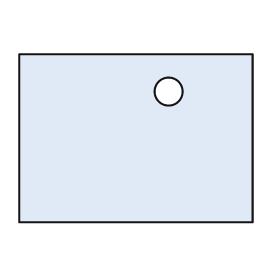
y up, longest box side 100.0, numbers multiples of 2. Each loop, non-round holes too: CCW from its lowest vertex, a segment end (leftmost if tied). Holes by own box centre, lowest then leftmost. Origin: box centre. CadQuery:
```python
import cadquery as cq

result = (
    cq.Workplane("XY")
    .moveTo(-50.0, -36.0)
    .lineTo(50.0, -36.0)
    .lineTo(50.0, 36.0)
    .lineTo(-50.0, 36.0)
    .close()
    .moveTo(14.0, 20.0)
    .circle(6.0)
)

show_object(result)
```